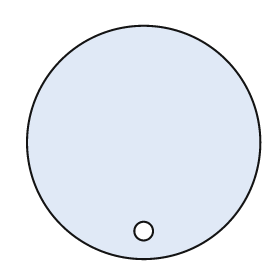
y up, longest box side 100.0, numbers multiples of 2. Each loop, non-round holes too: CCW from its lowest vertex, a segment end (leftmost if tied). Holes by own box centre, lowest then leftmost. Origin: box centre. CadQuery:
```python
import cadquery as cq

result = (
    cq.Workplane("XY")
    .moveTo(0.0, 0.0)
    .circle(50.0)
    .moveTo(0.0, -38.0)
    .circle(4.0)
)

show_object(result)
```